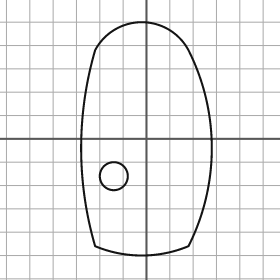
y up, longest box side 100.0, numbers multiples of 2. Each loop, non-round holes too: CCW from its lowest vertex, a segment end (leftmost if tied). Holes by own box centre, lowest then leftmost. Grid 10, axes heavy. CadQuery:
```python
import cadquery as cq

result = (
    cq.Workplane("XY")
    .moveTo(-22.0, -46.0)
    .threePointArc((-2.0, -50.0), (18.0, -46.0))
    .threePointArc((28.0, -4.0), (18.0, 38.0))
    .threePointArc((-2.0, 50.0), (-22.0, 38.0))
    .threePointArc((-28.0, -4.0), (-22.0, -46.0))
    .close()
    .moveTo(-14.0, -16.0)
    .circle(6.0)
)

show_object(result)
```